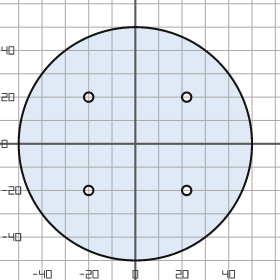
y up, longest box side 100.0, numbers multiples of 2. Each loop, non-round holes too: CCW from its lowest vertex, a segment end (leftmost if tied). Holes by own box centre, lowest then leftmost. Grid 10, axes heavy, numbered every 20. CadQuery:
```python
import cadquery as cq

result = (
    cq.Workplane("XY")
    .moveTo(0.0, 0.0)
    .circle(50.0)
    .moveTo(-20.0, -20.0)
    .circle(2.0)
    .moveTo(22.0, -20.0)
    .circle(2.0)
    .moveTo(-20.0, 20.0)
    .circle(2.0)
    .moveTo(22.0, 20.0)
    .circle(2.0)
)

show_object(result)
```